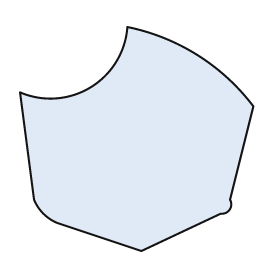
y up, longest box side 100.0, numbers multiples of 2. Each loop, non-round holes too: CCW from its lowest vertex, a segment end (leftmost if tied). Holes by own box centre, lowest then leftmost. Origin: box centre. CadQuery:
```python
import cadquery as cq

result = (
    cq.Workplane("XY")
    .moveTo(2.0, -48.0)
    .lineTo(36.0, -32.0)
    .threePointArc((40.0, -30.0), (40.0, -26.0))
    .lineTo(50.0, 14.0)
    .threePointArc((26.0, 36.0), (-4.0, 48.0))
    .threePointArc((-20.0, 22.0), (-50.0, 20.0))
    .lineTo(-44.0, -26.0)
    .threePointArc((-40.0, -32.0), (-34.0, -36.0))
    .close()
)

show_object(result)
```